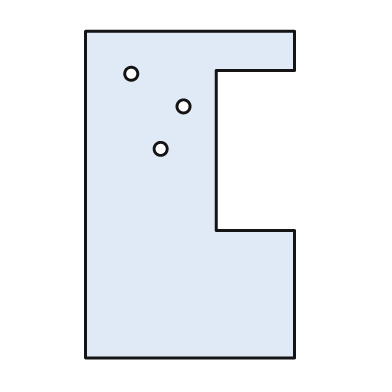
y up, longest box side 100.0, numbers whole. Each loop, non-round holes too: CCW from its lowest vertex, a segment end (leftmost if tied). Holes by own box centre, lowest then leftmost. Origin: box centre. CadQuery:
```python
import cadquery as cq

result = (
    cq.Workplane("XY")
    .moveTo(-32.0, -50.0)
    .lineTo(32.0, -50.0)
    .lineTo(32.0, -11.0)
    .lineTo(8.0, -11.0)
    .lineTo(8.0, 38.0)
    .lineTo(32.0, 38.0)
    .lineTo(32.0, 50.0)
    .lineTo(-32.0, 50.0)
    .close()
    .moveTo(-9.0, 14.0)
    .circle(2.0)
    .moveTo(-2.0, 27.0)
    .circle(2.0)
    .moveTo(-18.0, 37.0)
    .circle(2.0)
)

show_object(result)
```